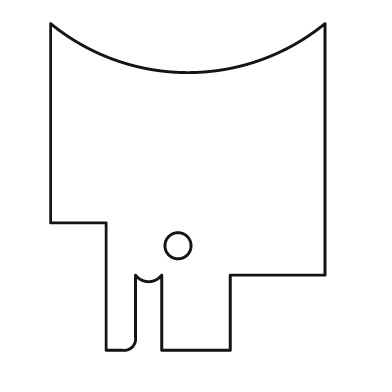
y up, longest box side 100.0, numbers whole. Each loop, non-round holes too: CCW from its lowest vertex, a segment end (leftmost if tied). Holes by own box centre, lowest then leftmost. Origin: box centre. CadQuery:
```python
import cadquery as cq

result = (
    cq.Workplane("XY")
    .moveTo(-25.0, -50.0)
    .lineTo(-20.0, -50.0)
    .threePointArc((-17.0, -49.0), (-16.0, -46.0))
    .lineTo(-16.0, -27.0)
    .threePointArc((-12.0, -29.0), (-8.0, -27.0))
    .lineTo(-8.0, -50.0)
    .lineTo(13.0, -50.0)
    .lineTo(13.0, -27.0)
    .lineTo(42.0, -27.0)
    .lineTo(42.0, 50.0)
    .threePointArc((0.0, 35.0), (-42.0, 50.0))
    .lineTo(-42.0, -11.0)
    .lineTo(-25.0, -11.0)
    .close()
    .moveTo(-3.0, -18.0)
    .circle(4.0)
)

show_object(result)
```